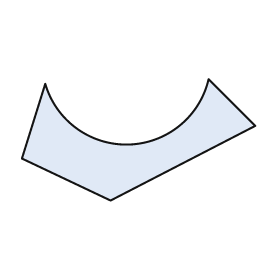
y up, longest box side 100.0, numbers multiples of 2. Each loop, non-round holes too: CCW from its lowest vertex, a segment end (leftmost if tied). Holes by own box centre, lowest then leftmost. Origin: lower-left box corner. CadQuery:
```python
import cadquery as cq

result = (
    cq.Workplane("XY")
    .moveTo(38.0, 0.0)
    .lineTo(100.0, 32.0)
    .lineTo(80.0, 52.0)
    .threePointArc((46.0, 24.0), (10.0, 50.0))
    .lineTo(0.0, 18.0)
    .close()
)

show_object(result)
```